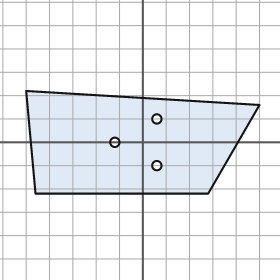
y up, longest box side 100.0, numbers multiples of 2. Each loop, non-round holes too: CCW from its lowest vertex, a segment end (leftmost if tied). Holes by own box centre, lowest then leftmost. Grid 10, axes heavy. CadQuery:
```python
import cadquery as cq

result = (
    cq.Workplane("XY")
    .moveTo(-46.0, -22.0)
    .lineTo(28.0, -22.0)
    .lineTo(50.0, 16.0)
    .lineTo(-50.0, 22.0)
    .close()
    .moveTo(6.0, -10.0)
    .circle(2.0)
    .moveTo(-12.0, 0.0)
    .circle(2.0)
    .moveTo(6.0, 10.0)
    .circle(2.0)
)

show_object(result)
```